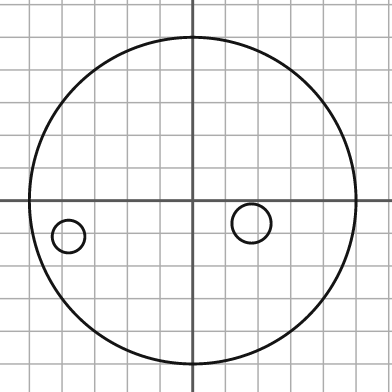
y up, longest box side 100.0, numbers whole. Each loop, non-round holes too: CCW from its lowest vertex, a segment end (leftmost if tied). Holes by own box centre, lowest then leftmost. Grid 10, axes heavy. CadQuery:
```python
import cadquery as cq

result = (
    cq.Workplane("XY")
    .moveTo(0.0, 0.0)
    .circle(50.0)
    .moveTo(-38.0, -11.0)
    .circle(5.0)
    .moveTo(18.0, -7.0)
    .circle(6.0)
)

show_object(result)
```